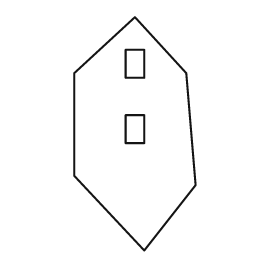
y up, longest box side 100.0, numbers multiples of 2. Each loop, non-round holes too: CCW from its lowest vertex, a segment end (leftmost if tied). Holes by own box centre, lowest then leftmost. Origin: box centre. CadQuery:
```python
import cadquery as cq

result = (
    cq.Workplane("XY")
    .moveTo(4.0, -50.0)
    .lineTo(26.0, -22.0)
    .lineTo(22.0, 26.0)
    .lineTo(0.0, 50.0)
    .lineTo(-26.0, 26.0)
    .lineTo(-26.0, -18.0)
    .close()
    .moveTo(-4.0, -4.0)
    .lineTo(4.0, -4.0)
    .lineTo(4.0, 8.0)
    .lineTo(-4.0, 8.0)
    .close()
    .moveTo(-4.0, 24.0)
    .lineTo(4.0, 24.0)
    .lineTo(4.0, 36.0)
    .lineTo(-4.0, 36.0)
    .close()
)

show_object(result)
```